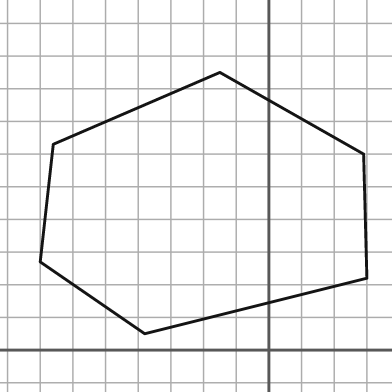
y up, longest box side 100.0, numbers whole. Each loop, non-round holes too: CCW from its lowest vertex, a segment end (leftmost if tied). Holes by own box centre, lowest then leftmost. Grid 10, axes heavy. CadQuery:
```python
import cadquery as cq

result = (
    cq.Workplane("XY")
    .moveTo(-38.0, 5.0)
    .lineTo(30.0, 22.0)
    .lineTo(29.0, 60.0)
    .lineTo(-15.0, 85.0)
    .lineTo(-66.0, 63.0)
    .lineTo(-70.0, 27.0)
    .close()
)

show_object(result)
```